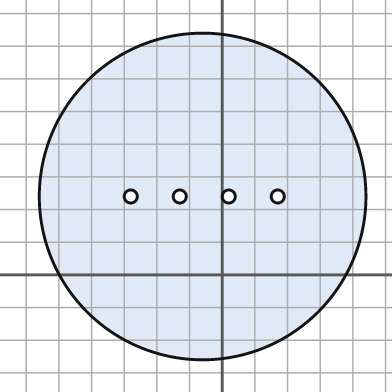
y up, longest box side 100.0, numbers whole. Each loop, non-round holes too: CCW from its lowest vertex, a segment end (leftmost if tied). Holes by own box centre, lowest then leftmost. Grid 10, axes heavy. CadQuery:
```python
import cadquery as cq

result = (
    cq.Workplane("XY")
    .moveTo(-6.0, 24.0)
    .circle(50.0)
    .moveTo(-28.0, 24.0)
    .circle(2.0)
    .moveTo(-13.0, 24.0)
    .circle(2.0)
    .moveTo(2.0, 24.0)
    .circle(2.0)
    .moveTo(17.0, 24.0)
    .circle(2.0)
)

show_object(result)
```